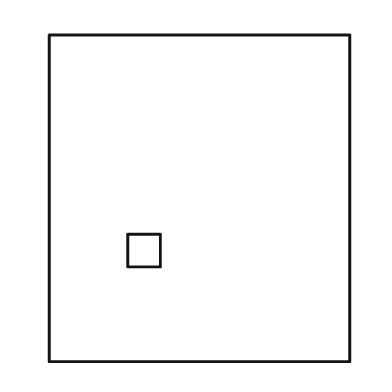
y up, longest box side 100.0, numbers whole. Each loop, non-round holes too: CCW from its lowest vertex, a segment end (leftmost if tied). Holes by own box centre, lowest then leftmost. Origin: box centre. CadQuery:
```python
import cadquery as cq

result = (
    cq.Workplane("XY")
    .moveTo(-46.0, -50.0)
    .lineTo(46.0, -50.0)
    .lineTo(46.0, 50.0)
    .lineTo(-46.0, 50.0)
    .close()
    .moveTo(-22.0, -21.0)
    .lineTo(-12.0, -21.0)
    .lineTo(-12.0, -11.0)
    .lineTo(-22.0, -11.0)
    .close()
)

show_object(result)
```